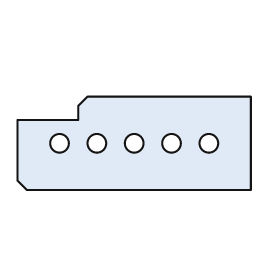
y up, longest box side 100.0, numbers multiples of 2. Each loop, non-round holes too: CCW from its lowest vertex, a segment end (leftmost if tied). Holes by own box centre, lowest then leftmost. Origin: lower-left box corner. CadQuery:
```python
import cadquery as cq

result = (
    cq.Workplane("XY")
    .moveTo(4.0, 0.0)
    .lineTo(100.0, 0.0)
    .lineTo(100.0, 40.0)
    .lineTo(30.0, 40.0)
    .lineTo(26.0, 36.0)
    .lineTo(26.0, 30.0)
    .lineTo(0.0, 30.0)
    .lineTo(0.0, 4.0)
    .close()
    .moveTo(18.0, 20.0)
    .circle(4.0)
    .moveTo(34.0, 20.0)
    .circle(4.0)
    .moveTo(50.0, 20.0)
    .circle(4.0)
    .moveTo(66.0, 20.0)
    .circle(4.0)
    .moveTo(82.0, 20.0)
    .circle(4.0)
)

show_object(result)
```